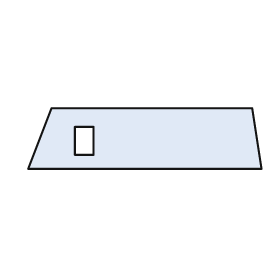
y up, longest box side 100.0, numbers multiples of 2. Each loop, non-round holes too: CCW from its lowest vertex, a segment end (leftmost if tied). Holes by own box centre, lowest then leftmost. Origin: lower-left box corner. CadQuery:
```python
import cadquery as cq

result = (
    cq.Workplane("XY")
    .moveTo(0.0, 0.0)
    .lineTo(100.0, 0.0)
    .lineTo(96.0, 26.0)
    .lineTo(10.0, 26.0)
    .close()
    .moveTo(20.0, 6.0)
    .lineTo(28.0, 6.0)
    .lineTo(28.0, 18.0)
    .lineTo(20.0, 18.0)
    .close()
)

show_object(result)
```